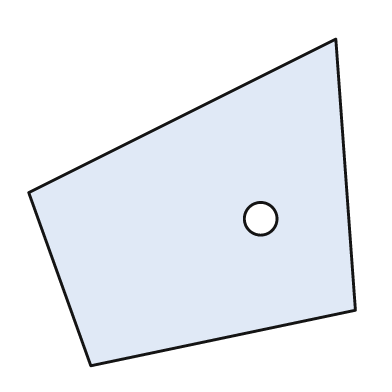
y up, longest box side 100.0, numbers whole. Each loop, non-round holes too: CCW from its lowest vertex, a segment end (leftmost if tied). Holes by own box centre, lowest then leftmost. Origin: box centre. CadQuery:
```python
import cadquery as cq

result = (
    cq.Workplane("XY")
    .moveTo(-31.0, -50.0)
    .lineTo(50.0, -33.0)
    .lineTo(44.0, 50.0)
    .lineTo(-50.0, 3.0)
    .close()
    .moveTo(21.0, -5.0)
    .circle(5.0)
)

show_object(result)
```